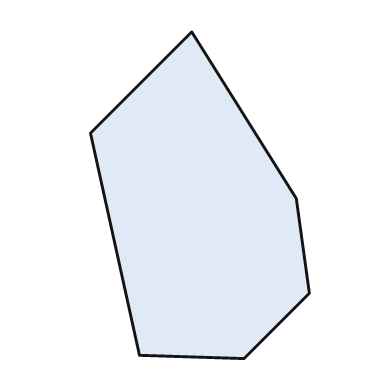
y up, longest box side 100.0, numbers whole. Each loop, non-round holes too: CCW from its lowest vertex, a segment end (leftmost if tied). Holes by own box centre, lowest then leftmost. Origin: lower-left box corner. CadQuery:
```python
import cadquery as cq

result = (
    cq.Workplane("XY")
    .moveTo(47.0, 0.0)
    .lineTo(67.0, 20.0)
    .lineTo(63.0, 49.0)
    .lineTo(31.0, 100.0)
    .lineTo(0.0, 69.0)
    .lineTo(15.0, 1.0)
    .close()
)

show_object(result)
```